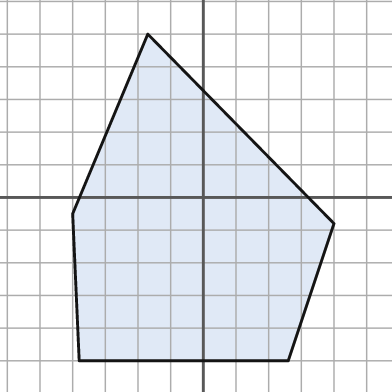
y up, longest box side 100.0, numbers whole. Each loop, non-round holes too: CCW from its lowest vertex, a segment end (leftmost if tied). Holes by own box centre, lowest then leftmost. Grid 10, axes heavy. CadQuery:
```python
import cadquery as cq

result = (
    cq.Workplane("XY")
    .moveTo(-38.0, -50.0)
    .lineTo(26.0, -50.0)
    .lineTo(40.0, -8.0)
    .lineTo(-17.0, 50.0)
    .lineTo(-40.0, -5.0)
    .close()
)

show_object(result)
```